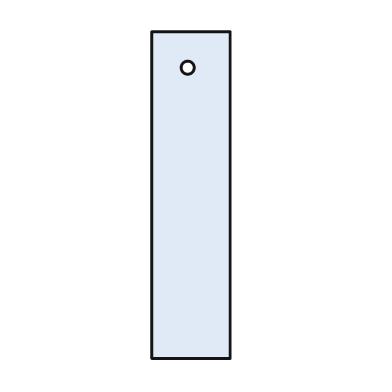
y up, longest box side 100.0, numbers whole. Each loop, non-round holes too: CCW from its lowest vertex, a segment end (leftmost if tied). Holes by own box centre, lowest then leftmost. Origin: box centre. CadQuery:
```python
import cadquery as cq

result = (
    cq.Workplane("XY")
    .moveTo(-12.0, -50.0)
    .lineTo(12.0, -50.0)
    .lineTo(12.0, 50.0)
    .lineTo(-12.0, 50.0)
    .close()
    .moveTo(-1.0, 39.0)
    .circle(2.0)
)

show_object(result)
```